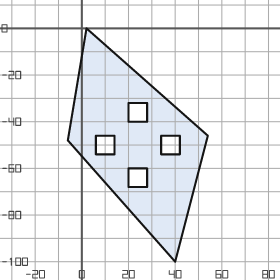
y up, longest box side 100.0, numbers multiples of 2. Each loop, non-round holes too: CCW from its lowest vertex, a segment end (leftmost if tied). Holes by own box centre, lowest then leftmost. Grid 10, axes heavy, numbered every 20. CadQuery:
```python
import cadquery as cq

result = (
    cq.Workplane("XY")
    .moveTo(40.0, -100.0)
    .lineTo(54.0, -46.0)
    .lineTo(2.0, 0.0)
    .lineTo(-6.0, -48.0)
    .close()
    .moveTo(20.0, -68.0)
    .lineTo(28.0, -68.0)
    .lineTo(28.0, -60.0)
    .lineTo(20.0, -60.0)
    .close()
    .moveTo(6.0, -54.0)
    .lineTo(14.0, -54.0)
    .lineTo(14.0, -46.0)
    .lineTo(6.0, -46.0)
    .close()
    .moveTo(34.0, -54.0)
    .lineTo(42.0, -54.0)
    .lineTo(42.0, -46.0)
    .lineTo(34.0, -46.0)
    .close()
    .moveTo(20.0, -40.0)
    .lineTo(28.0, -40.0)
    .lineTo(28.0, -32.0)
    .lineTo(20.0, -32.0)
    .close()
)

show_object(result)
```